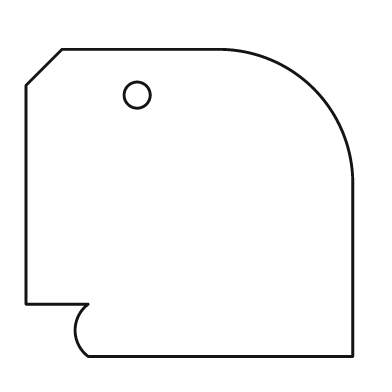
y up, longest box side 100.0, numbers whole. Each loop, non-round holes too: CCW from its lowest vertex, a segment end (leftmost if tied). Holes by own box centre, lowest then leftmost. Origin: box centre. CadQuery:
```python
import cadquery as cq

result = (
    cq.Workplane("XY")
    .moveTo(-31.0, -47.0)
    .lineTo(50.0, -47.0)
    .lineTo(50.0, 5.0)
    .threePointArc((38.0, 35.0), (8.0, 47.0))
    .lineTo(-39.0, 47.0)
    .lineTo(-50.0, 36.0)
    .lineTo(-50.0, -31.0)
    .lineTo(-31.0, -31.0)
    .threePointArc((-35.0, -39.0), (-31.0, -47.0))
    .close()
    .moveTo(-16.0, 33.0)
    .circle(4.0)
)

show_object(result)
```